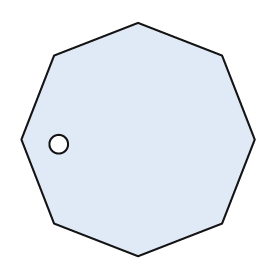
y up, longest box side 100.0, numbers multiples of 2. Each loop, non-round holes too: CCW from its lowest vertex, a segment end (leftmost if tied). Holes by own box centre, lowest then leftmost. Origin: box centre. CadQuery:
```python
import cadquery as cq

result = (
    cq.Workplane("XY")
    .moveTo(0.0, -50.0)
    .lineTo(36.0, -36.0)
    .lineTo(50.0, 0.0)
    .lineTo(36.0, 36.0)
    .lineTo(0.0, 50.0)
    .lineTo(-36.0, 36.0)
    .lineTo(-50.0, 0.0)
    .lineTo(-36.0, -36.0)
    .close()
    .moveTo(-34.0, -2.0)
    .circle(4.0)
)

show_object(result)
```